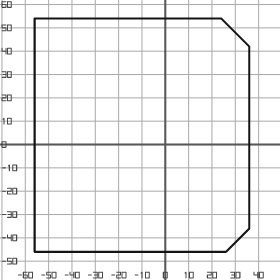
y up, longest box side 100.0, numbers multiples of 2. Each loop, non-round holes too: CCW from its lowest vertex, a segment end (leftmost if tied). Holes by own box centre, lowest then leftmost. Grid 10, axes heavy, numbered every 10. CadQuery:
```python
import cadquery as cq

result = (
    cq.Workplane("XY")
    .moveTo(-56.0, -46.0)
    .lineTo(26.0, -46.0)
    .lineTo(36.0, -36.0)
    .lineTo(36.0, 42.0)
    .lineTo(24.0, 54.0)
    .lineTo(-56.0, 54.0)
    .close()
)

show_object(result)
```